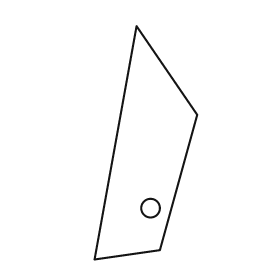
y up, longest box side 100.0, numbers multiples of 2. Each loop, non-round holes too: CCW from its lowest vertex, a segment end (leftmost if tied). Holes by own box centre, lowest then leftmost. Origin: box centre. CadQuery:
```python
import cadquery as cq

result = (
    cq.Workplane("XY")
    .moveTo(-22.0, -50.0)
    .lineTo(6.0, -46.0)
    .lineTo(22.0, 12.0)
    .lineTo(-4.0, 50.0)
    .close()
    .moveTo(2.0, -28.0)
    .circle(4.0)
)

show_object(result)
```